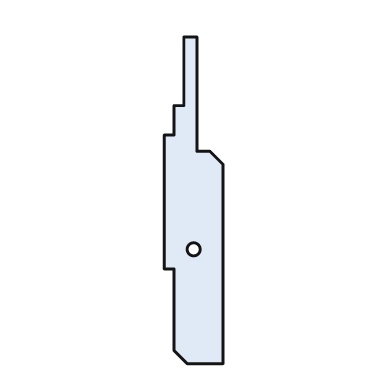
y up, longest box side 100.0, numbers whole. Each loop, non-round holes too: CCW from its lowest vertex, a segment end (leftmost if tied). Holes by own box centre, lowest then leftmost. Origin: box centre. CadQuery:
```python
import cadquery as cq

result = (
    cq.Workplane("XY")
    .moveTo(-2.0, -50.0)
    .lineTo(9.0, -50.0)
    .lineTo(9.0, 11.0)
    .lineTo(5.0, 15.0)
    .lineTo(1.0, 15.0)
    .lineTo(1.0, 50.0)
    .lineTo(-3.0, 50.0)
    .lineTo(-3.0, 29.0)
    .lineTo(-6.0, 29.0)
    .lineTo(-6.0, 20.0)
    .lineTo(-9.0, 20.0)
    .lineTo(-9.0, -21.0)
    .lineTo(-6.0, -21.0)
    .lineTo(-6.0, -46.0)
    .close()
    .moveTo(0.0, -15.0)
    .circle(2.0)
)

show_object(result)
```